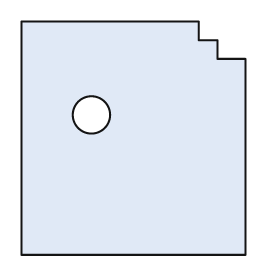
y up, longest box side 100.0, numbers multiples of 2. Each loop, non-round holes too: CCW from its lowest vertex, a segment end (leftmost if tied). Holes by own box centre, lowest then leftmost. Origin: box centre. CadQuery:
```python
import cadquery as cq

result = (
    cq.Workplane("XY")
    .moveTo(-48.0, -50.0)
    .lineTo(48.0, -50.0)
    .lineTo(48.0, 34.0)
    .lineTo(36.0, 34.0)
    .lineTo(36.0, 42.0)
    .lineTo(28.0, 42.0)
    .lineTo(28.0, 50.0)
    .lineTo(-48.0, 50.0)
    .close()
    .moveTo(-18.0, 10.0)
    .circle(8.0)
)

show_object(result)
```